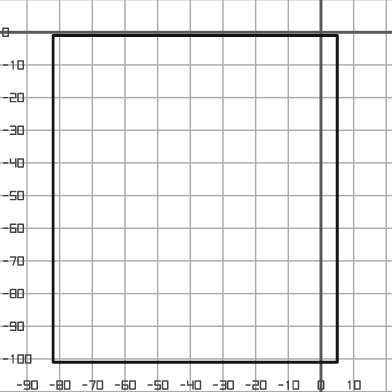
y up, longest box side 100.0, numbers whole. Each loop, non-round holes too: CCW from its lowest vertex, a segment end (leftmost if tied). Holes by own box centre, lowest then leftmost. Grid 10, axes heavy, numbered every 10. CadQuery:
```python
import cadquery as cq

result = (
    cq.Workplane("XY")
    .moveTo(-82.0, -101.0)
    .lineTo(5.0, -101.0)
    .lineTo(5.0, -1.0)
    .lineTo(-82.0, -1.0)
    .close()
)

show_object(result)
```